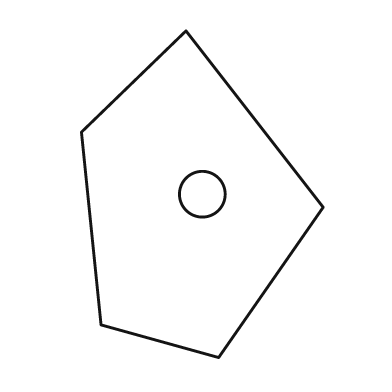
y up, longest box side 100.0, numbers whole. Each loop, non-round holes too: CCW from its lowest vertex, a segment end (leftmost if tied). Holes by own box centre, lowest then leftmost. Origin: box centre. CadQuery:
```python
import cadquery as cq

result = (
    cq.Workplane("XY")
    .moveTo(5.0, -50.0)
    .lineTo(37.0, -4.0)
    .lineTo(-5.0, 50.0)
    .lineTo(-37.0, 19.0)
    .lineTo(-31.0, -40.0)
    .close()
    .moveTo(0.0, 0.0)
    .circle(7.0)
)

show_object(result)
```